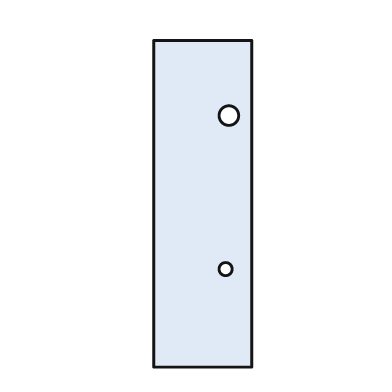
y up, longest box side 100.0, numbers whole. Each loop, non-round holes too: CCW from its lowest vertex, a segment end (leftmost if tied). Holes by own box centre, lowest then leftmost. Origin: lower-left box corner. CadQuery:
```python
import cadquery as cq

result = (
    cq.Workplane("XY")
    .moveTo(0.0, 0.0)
    .lineTo(30.0, 0.0)
    .lineTo(30.0, 100.0)
    .lineTo(0.0, 100.0)
    .close()
    .moveTo(22.0, 30.0)
    .circle(2.0)
    .moveTo(23.0, 77.0)
    .circle(3.0)
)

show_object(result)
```